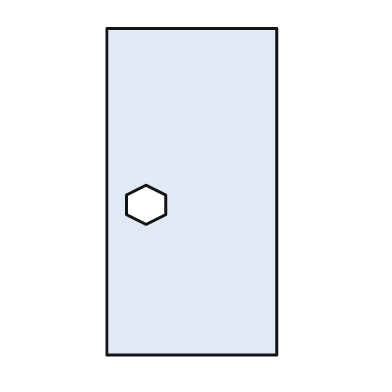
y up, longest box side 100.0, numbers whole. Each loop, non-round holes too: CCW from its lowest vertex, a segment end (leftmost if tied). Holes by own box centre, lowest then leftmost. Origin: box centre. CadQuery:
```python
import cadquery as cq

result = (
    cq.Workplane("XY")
    .moveTo(-26.0, -50.0)
    .lineTo(26.0, -50.0)
    .lineTo(26.0, 50.0)
    .lineTo(-26.0, 50.0)
    .close()
    .moveTo(-14.0, -10.0)
    .lineTo(-8.0, -7.0)
    .lineTo(-8.0, -1.0)
    .lineTo(-14.0, 2.0)
    .lineTo(-20.0, -1.0)
    .lineTo(-20.0, -7.0)
    .close()
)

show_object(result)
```